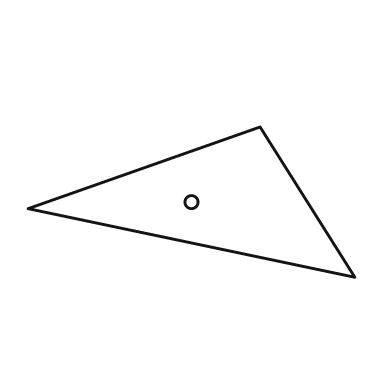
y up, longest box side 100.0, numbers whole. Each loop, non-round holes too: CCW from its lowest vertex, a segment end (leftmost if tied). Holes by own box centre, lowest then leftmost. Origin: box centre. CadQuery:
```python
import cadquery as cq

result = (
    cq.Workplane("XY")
    .moveTo(50.0, -23.0)
    .lineTo(21.0, 23.0)
    .lineTo(-50.0, -2.0)
    .close()
    .moveTo(0.0, 0.0)
    .circle(2.0)
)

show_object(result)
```